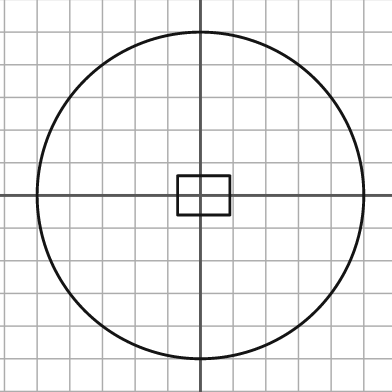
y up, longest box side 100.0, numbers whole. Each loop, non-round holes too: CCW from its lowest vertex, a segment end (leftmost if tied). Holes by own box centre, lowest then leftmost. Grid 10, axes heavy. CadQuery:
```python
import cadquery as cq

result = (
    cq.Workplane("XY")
    .moveTo(0.0, 0.0)
    .circle(50.0)
    .moveTo(-7.0, -6.0)
    .lineTo(9.0, -6.0)
    .lineTo(9.0, 6.0)
    .lineTo(-7.0, 6.0)
    .close()
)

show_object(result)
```